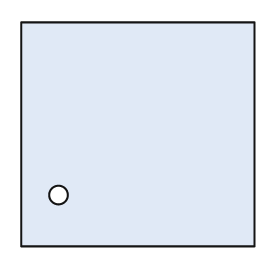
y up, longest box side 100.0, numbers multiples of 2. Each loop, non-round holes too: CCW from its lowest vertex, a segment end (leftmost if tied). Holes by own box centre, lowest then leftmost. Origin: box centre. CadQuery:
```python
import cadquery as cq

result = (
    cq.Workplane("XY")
    .moveTo(-50.0, -48.0)
    .lineTo(50.0, -48.0)
    .lineTo(50.0, 48.0)
    .lineTo(-50.0, 48.0)
    .close()
    .moveTo(-34.0, -26.0)
    .circle(4.0)
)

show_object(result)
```